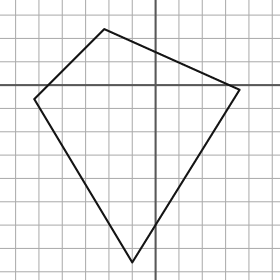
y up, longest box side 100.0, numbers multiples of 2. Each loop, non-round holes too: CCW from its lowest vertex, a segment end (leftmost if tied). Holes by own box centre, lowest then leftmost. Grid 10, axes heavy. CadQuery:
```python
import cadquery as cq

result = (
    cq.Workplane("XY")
    .moveTo(-10.0, -76.0)
    .lineTo(36.0, -2.0)
    .lineTo(-22.0, 24.0)
    .lineTo(-52.0, -6.0)
    .close()
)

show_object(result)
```